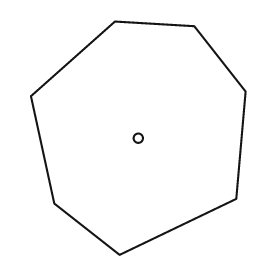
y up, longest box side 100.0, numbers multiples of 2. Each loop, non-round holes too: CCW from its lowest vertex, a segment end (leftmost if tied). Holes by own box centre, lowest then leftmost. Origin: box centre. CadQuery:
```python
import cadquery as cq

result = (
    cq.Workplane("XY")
    .moveTo(-8.0, -50.0)
    .lineTo(42.0, -26.0)
    .lineTo(46.0, 20.0)
    .lineTo(24.0, 48.0)
    .lineTo(-10.0, 50.0)
    .lineTo(-46.0, 18.0)
    .lineTo(-36.0, -28.0)
    .close()
    .moveTo(0.0, 0.0)
    .circle(2.0)
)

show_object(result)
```